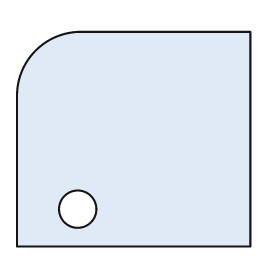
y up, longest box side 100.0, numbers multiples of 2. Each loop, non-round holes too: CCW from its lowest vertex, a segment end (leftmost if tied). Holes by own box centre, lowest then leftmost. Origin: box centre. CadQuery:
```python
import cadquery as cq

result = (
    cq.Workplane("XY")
    .moveTo(-50.0, -46.0)
    .lineTo(50.0, -46.0)
    .lineTo(50.0, 46.0)
    .lineTo(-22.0, 46.0)
    .threePointArc((-42.0, 38.0), (-50.0, 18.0))
    .close()
    .moveTo(-24.0, -30.0)
    .circle(8.0)
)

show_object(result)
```